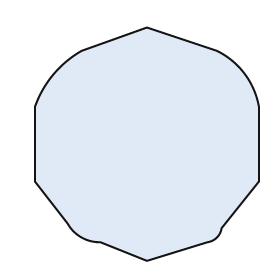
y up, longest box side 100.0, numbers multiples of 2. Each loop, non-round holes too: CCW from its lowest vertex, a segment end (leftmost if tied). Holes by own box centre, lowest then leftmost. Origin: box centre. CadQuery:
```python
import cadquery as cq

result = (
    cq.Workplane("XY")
    .moveTo(0.0, -50.0)
    .lineTo(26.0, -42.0)
    .threePointArc((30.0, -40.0), (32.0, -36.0))
    .lineTo(48.0, -16.0)
    .lineTo(48.0, 16.0)
    .threePointArc((42.0, 30.0), (30.0, 40.0))
    .lineTo(0.0, 50.0)
    .lineTo(-28.0, 40.0)
    .threePointArc((-40.0, 30.0), (-48.0, 16.0))
    .lineTo(-48.0, -16.0)
    .lineTo(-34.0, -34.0)
    .threePointArc((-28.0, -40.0), (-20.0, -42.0))
    .close()
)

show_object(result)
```